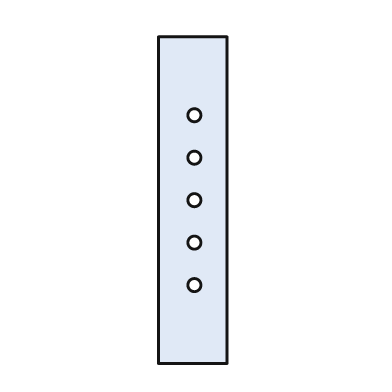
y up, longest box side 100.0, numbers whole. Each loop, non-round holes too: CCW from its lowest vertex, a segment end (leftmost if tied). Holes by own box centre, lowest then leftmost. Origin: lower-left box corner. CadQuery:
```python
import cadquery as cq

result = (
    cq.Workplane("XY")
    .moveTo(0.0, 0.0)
    .lineTo(21.0, 0.0)
    .lineTo(21.0, 100.0)
    .lineTo(0.0, 100.0)
    .close()
    .moveTo(11.0, 24.0)
    .circle(2.0)
    .moveTo(11.0, 37.0)
    .circle(2.0)
    .moveTo(11.0, 50.0)
    .circle(2.0)
    .moveTo(11.0, 63.0)
    .circle(2.0)
    .moveTo(11.0, 76.0)
    .circle(2.0)
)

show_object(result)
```